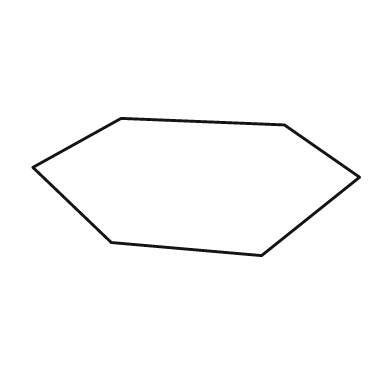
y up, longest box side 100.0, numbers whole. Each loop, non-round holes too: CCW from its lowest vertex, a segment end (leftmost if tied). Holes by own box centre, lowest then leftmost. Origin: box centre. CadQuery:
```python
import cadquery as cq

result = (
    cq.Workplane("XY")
    .moveTo(20.0, -21.0)
    .lineTo(50.0, 3.0)
    .lineTo(27.0, 19.0)
    .lineTo(-23.0, 21.0)
    .lineTo(-50.0, 6.0)
    .lineTo(-26.0, -17.0)
    .close()
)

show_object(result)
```